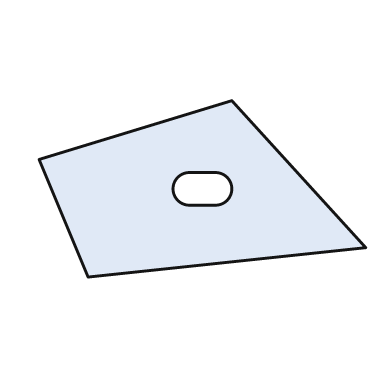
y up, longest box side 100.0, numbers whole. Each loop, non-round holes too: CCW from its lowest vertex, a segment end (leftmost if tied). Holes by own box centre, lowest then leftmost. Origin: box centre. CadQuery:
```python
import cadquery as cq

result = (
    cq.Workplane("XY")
    .moveTo(-35.0, -27.0)
    .lineTo(50.0, -18.0)
    .lineTo(9.0, 27.0)
    .lineTo(-50.0, 9.0)
    .close()
    .moveTo(-4.0, -5.0)
    .lineTo(4.0, -5.0)
    .threePointArc((9.0, 0.0), (4.0, 5.0))
    .lineTo(-4.0, 5.0)
    .threePointArc((-9.0, 0.0), (-4.0, -5.0))
    .close()
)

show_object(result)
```